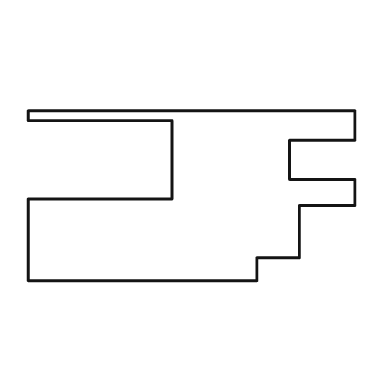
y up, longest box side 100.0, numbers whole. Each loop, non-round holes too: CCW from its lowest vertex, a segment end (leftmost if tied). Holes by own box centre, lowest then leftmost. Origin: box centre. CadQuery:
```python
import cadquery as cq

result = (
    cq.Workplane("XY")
    .moveTo(-50.0, -26.0)
    .lineTo(20.0, -26.0)
    .lineTo(20.0, -19.0)
    .lineTo(33.0, -19.0)
    .lineTo(33.0, -3.0)
    .lineTo(50.0, -3.0)
    .lineTo(50.0, 5.0)
    .lineTo(30.0, 5.0)
    .lineTo(30.0, 17.0)
    .lineTo(50.0, 17.0)
    .lineTo(50.0, 26.0)
    .lineTo(-50.0, 26.0)
    .lineTo(-50.0, 23.0)
    .lineTo(-6.0, 23.0)
    .lineTo(-6.0, -1.0)
    .lineTo(-50.0, -1.0)
    .close()
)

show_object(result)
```